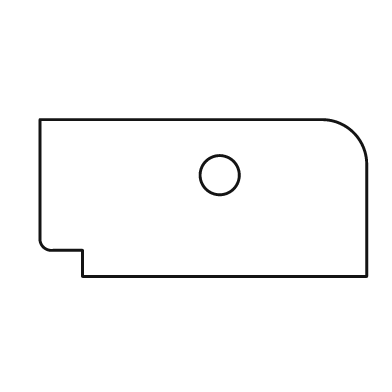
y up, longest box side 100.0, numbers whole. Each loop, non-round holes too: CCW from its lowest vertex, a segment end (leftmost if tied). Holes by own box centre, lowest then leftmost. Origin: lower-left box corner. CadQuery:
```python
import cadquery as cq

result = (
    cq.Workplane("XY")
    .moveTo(13.0, 0.0)
    .lineTo(100.0, 0.0)
    .lineTo(100.0, 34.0)
    .threePointArc((96.0, 44.0), (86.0, 48.0))
    .lineTo(0.0, 48.0)
    .lineTo(0.0, 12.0)
    .threePointArc((1.0, 9.0), (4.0, 8.0))
    .lineTo(13.0, 8.0)
    .close()
    .moveTo(55.0, 31.0)
    .circle(6.0)
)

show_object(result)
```